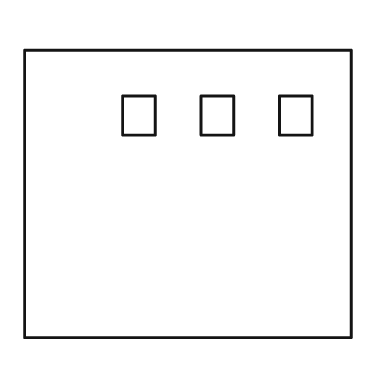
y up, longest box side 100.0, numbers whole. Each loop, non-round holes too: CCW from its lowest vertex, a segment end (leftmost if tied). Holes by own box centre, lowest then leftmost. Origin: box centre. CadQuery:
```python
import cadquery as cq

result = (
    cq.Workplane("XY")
    .moveTo(-50.0, -44.0)
    .lineTo(50.0, -44.0)
    .lineTo(50.0, 44.0)
    .lineTo(-50.0, 44.0)
    .close()
    .moveTo(-20.0, 18.0)
    .lineTo(-10.0, 18.0)
    .lineTo(-10.0, 30.0)
    .lineTo(-20.0, 30.0)
    .close()
    .moveTo(4.0, 18.0)
    .lineTo(14.0, 18.0)
    .lineTo(14.0, 30.0)
    .lineTo(4.0, 30.0)
    .close()
    .moveTo(28.0, 18.0)
    .lineTo(38.0, 18.0)
    .lineTo(38.0, 30.0)
    .lineTo(28.0, 30.0)
    .close()
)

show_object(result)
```